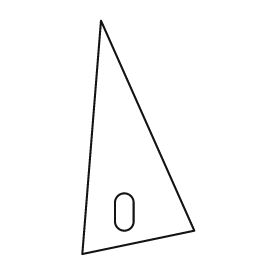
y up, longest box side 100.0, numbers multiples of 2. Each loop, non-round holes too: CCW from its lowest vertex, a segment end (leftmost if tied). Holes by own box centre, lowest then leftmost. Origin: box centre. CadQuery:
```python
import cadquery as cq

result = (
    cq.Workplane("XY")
    .moveTo(-24.0, -50.0)
    .lineTo(24.0, -40.0)
    .lineTo(-16.0, 50.0)
    .close()
    .moveTo(-10.0, -36.0)
    .threePointArc((-6.0, -40.0), (-2.0, -36.0))
    .lineTo(-2.0, -28.0)
    .threePointArc((-6.0, -24.0), (-10.0, -28.0))
    .close()
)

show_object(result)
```